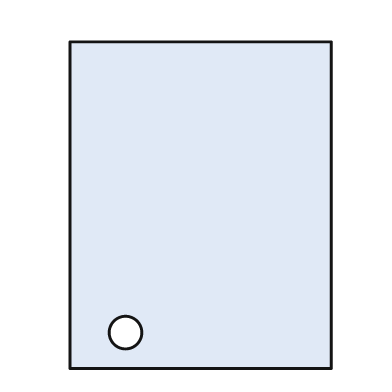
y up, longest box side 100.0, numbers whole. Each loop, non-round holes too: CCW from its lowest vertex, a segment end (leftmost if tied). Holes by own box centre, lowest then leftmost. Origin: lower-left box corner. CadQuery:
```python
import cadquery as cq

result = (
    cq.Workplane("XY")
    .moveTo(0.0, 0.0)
    .lineTo(80.0, 0.0)
    .lineTo(80.0, 100.0)
    .lineTo(0.0, 100.0)
    .close()
    .moveTo(17.0, 11.0)
    .circle(5.0)
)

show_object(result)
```